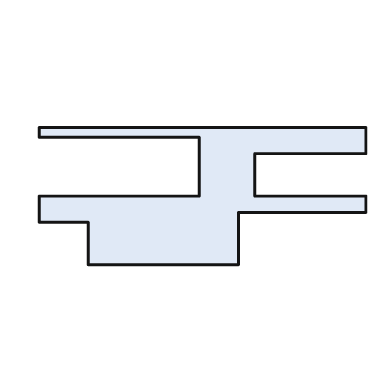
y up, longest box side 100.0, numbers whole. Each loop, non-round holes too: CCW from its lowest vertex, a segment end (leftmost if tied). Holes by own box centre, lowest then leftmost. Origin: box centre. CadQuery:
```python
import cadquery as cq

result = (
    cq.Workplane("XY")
    .moveTo(-35.0, -21.0)
    .lineTo(11.0, -21.0)
    .lineTo(11.0, -5.0)
    .lineTo(50.0, -5.0)
    .lineTo(50.0, 0.0)
    .lineTo(16.0, 0.0)
    .lineTo(16.0, 13.0)
    .lineTo(50.0, 13.0)
    .lineTo(50.0, 21.0)
    .lineTo(-50.0, 21.0)
    .lineTo(-50.0, 18.0)
    .lineTo(-1.0, 18.0)
    .lineTo(-1.0, 0.0)
    .lineTo(-50.0, 0.0)
    .lineTo(-50.0, -8.0)
    .lineTo(-35.0, -8.0)
    .close()
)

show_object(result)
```